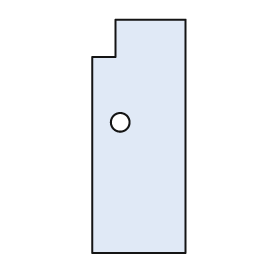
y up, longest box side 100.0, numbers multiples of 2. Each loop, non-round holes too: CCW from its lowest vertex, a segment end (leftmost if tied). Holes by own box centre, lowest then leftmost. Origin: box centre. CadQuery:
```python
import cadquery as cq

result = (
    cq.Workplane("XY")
    .moveTo(-20.0, -50.0)
    .lineTo(20.0, -50.0)
    .lineTo(20.0, 50.0)
    .lineTo(-10.0, 50.0)
    .lineTo(-10.0, 34.0)
    .lineTo(-20.0, 34.0)
    .close()
    .moveTo(-8.0, 6.0)
    .circle(4.0)
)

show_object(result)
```